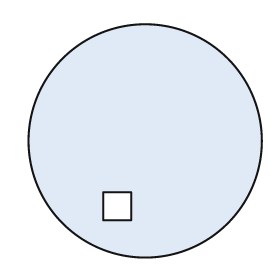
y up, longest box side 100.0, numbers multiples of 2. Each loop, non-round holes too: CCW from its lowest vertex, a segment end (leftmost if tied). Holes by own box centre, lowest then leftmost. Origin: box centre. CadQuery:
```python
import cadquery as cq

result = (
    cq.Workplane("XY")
    .moveTo(0.0, 0.0)
    .circle(50.0)
    .moveTo(-18.0, -34.0)
    .lineTo(-6.0, -34.0)
    .lineTo(-6.0, -22.0)
    .lineTo(-18.0, -22.0)
    .close()
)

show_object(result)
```